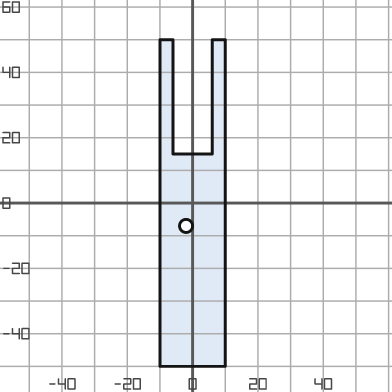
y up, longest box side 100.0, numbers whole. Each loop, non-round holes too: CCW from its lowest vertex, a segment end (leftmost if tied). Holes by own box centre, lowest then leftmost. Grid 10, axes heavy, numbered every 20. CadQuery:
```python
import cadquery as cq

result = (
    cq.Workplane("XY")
    .moveTo(-10.0, -50.0)
    .lineTo(10.0, -50.0)
    .lineTo(10.0, 50.0)
    .lineTo(6.0, 50.0)
    .lineTo(6.0, 15.0)
    .lineTo(-6.0, 15.0)
    .lineTo(-6.0, 50.0)
    .lineTo(-10.0, 50.0)
    .close()
    .moveTo(-2.0, -7.0)
    .circle(2.0)
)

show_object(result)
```